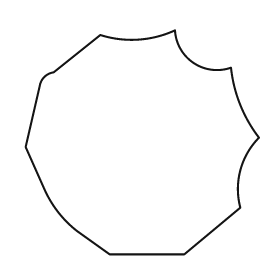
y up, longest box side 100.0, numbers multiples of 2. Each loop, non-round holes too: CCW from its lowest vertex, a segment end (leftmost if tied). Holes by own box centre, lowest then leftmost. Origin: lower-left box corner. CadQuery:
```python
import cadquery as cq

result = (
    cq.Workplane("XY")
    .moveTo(36.0, 0.0)
    .lineTo(68.0, 0.0)
    .lineTo(92.0, 20.0)
    .threePointArc((92.0, 36.0), (100.0, 50.0))
    .threePointArc((92.0, 64.0), (88.0, 80.0))
    .threePointArc((72.0, 82.0), (64.0, 96.0))
    .threePointArc((48.0, 92.0), (32.0, 94.0))
    .lineTo(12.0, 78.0)
    .threePointArc((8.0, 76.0), (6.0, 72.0))
    .lineTo(0.0, 46.0)
    .lineTo(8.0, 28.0)
    .threePointArc((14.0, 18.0), (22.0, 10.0))
    .close()
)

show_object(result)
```